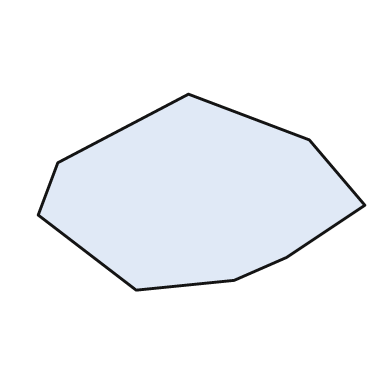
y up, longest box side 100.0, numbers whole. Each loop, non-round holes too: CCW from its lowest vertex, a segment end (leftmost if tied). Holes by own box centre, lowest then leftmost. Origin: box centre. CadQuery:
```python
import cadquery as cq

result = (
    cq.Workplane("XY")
    .moveTo(-20.0, -30.0)
    .lineTo(10.0, -27.0)
    .lineTo(26.0, -20.0)
    .lineTo(50.0, -4.0)
    .lineTo(33.0, 16.0)
    .lineTo(-4.0, 30.0)
    .lineTo(-44.0, 9.0)
    .lineTo(-50.0, -7.0)
    .close()
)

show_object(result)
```